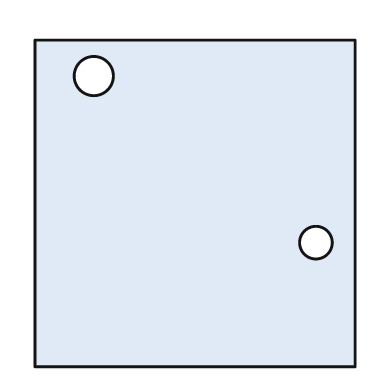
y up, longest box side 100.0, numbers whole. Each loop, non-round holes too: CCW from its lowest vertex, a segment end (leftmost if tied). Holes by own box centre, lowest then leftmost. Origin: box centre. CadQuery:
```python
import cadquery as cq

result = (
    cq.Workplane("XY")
    .moveTo(-49.0, -50.0)
    .lineTo(49.0, -50.0)
    .lineTo(49.0, 50.0)
    .lineTo(-49.0, 50.0)
    .close()
    .moveTo(37.0, -12.0)
    .circle(5.0)
    .moveTo(-31.0, 39.0)
    .circle(6.0)
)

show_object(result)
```